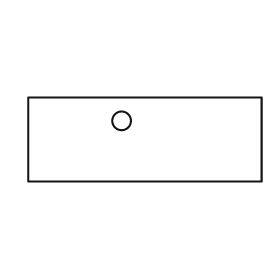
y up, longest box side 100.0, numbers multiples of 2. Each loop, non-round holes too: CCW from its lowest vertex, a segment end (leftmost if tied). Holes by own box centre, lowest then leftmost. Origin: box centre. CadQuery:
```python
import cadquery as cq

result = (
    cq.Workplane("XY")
    .moveTo(-50.0, -18.0)
    .lineTo(50.0, -18.0)
    .lineTo(50.0, 18.0)
    .lineTo(-50.0, 18.0)
    .close()
    .moveTo(-10.0, 8.0)
    .circle(4.0)
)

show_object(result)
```